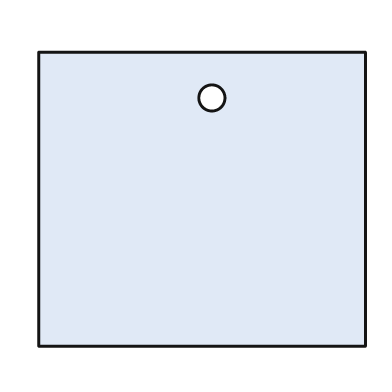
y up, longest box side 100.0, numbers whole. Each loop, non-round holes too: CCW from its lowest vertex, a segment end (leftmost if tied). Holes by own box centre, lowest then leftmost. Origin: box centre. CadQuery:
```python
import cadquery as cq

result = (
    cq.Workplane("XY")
    .moveTo(-50.0, -45.0)
    .lineTo(50.0, -45.0)
    .lineTo(50.0, 45.0)
    .lineTo(-50.0, 45.0)
    .close()
    .moveTo(3.0, 31.0)
    .circle(4.0)
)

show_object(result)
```